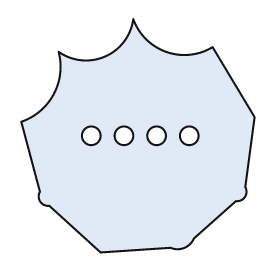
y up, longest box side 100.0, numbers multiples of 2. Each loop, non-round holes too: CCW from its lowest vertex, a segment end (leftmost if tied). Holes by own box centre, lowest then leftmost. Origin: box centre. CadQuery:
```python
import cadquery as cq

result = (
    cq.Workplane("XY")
    .moveTo(-16.0, -50.0)
    .lineTo(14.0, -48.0)
    .threePointArc((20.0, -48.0), (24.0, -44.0))
    .lineTo(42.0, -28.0)
    .threePointArc((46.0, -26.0), (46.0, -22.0))
    .lineTo(50.0, 8.0)
    .lineTo(32.0, 38.0)
    .threePointArc((12.0, 36.0), (-2.0, 50.0))
    .threePointArc((-14.0, 34.0), (-34.0, 36.0))
    .threePointArc((-36.0, 18.0), (-50.0, 6.0))
    .lineTo(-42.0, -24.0)
    .threePointArc((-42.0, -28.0), (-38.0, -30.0))
    .close()
    .moveTo(-20.0, 0.0)
    .circle(4.0)
    .moveTo(-6.0, 0.0)
    .circle(4.0)
    .moveTo(8.0, 0.0)
    .circle(4.0)
    .moveTo(22.0, 0.0)
    .circle(4.0)
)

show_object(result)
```